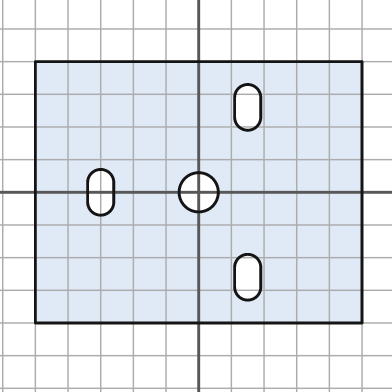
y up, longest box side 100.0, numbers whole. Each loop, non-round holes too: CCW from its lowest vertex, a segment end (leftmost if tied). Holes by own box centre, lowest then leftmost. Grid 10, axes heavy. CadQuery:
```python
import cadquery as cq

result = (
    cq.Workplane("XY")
    .moveTo(-50.0, -40.0)
    .lineTo(50.0, -40.0)
    .lineTo(50.0, 40.0)
    .lineTo(-50.0, 40.0)
    .close()
    .moveTo(11.0, -29.0)
    .threePointArc((15.0, -33.0), (19.0, -29.0))
    .lineTo(19.0, -23.0)
    .threePointArc((15.0, -19.0), (11.0, -23.0))
    .close()
    .moveTo(-34.0, -3.0)
    .threePointArc((-30.0, -7.0), (-26.0, -3.0))
    .lineTo(-26.0, 3.0)
    .threePointArc((-30.0, 7.0), (-34.0, 3.0))
    .close()
    .moveTo(0.0, 0.0)
    .circle(6.0)
    .moveTo(11.0, 23.0)
    .threePointArc((15.0, 19.0), (19.0, 23.0))
    .lineTo(19.0, 29.0)
    .threePointArc((15.0, 33.0), (11.0, 29.0))
    .close()
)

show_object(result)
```